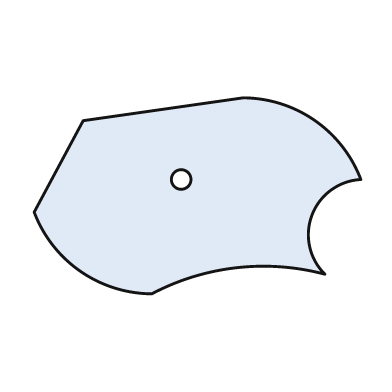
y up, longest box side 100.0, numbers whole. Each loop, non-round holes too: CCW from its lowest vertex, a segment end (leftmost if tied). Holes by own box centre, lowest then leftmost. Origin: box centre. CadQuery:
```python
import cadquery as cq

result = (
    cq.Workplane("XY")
    .moveTo(-14.0, -30.0)
    .threePointArc((12.0, -22.0), (39.0, -24.0))
    .threePointArc((35.0, -6.0), (50.0, 5.0))
    .threePointArc((36.0, 23.0), (14.0, 30.0))
    .lineTo(-35.0, 23.0)
    .lineTo(-50.0, -5.0)
    .threePointArc((-36.0, -23.0), (-14.0, -30.0))
    .close()
    .moveTo(-5.0, 5.0)
    .circle(3.0)
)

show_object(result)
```